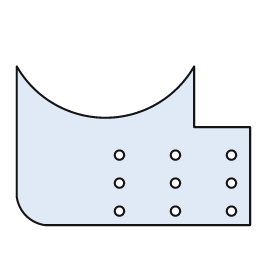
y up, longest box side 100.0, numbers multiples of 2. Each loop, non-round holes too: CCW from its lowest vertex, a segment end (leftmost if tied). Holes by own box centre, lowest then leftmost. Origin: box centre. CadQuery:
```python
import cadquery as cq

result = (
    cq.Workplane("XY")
    .moveTo(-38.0, -34.0)
    .lineTo(50.0, -34.0)
    .lineTo(50.0, 8.0)
    .lineTo(26.0, 8.0)
    .lineTo(26.0, 34.0)
    .threePointArc((-12.0, 12.0), (-50.0, 34.0))
    .lineTo(-50.0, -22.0)
    .threePointArc((-46.0, -30.0), (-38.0, -34.0))
    .close()
    .moveTo(-6.0, -28.0)
    .circle(2.0)
    .moveTo(18.0, -28.0)
    .circle(2.0)
    .moveTo(42.0, -28.0)
    .circle(2.0)
    .moveTo(-6.0, -16.0)
    .circle(2.0)
    .moveTo(18.0, -16.0)
    .circle(2.0)
    .moveTo(42.0, -16.0)
    .circle(2.0)
    .moveTo(-6.0, -4.0)
    .circle(2.0)
    .moveTo(18.0, -4.0)
    .circle(2.0)
    .moveTo(42.0, -4.0)
    .circle(2.0)
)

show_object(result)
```